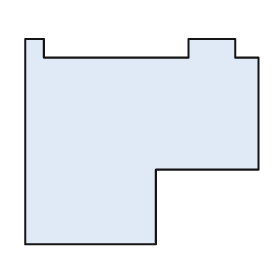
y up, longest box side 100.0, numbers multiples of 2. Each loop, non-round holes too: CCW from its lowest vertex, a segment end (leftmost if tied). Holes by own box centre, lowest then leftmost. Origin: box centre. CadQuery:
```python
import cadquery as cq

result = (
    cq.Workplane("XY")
    .moveTo(-50.0, -44.0)
    .lineTo(6.0, -44.0)
    .lineTo(6.0, -12.0)
    .lineTo(50.0, -12.0)
    .lineTo(50.0, 36.0)
    .lineTo(40.0, 36.0)
    .lineTo(40.0, 44.0)
    .lineTo(20.0, 44.0)
    .lineTo(20.0, 36.0)
    .lineTo(-42.0, 36.0)
    .lineTo(-42.0, 44.0)
    .lineTo(-50.0, 44.0)
    .close()
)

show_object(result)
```